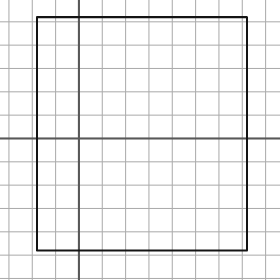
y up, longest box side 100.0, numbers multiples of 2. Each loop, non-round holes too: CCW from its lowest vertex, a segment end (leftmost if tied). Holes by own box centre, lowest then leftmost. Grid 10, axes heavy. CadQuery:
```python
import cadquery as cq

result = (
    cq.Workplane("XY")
    .moveTo(-18.0, -48.0)
    .lineTo(72.0, -48.0)
    .lineTo(72.0, 52.0)
    .lineTo(-18.0, 52.0)
    .close()
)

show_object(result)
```